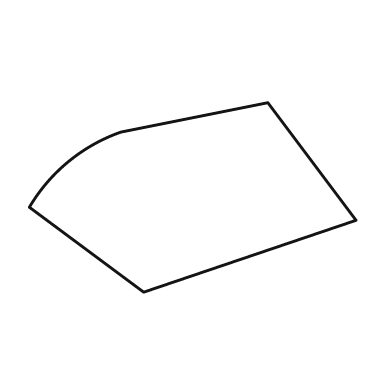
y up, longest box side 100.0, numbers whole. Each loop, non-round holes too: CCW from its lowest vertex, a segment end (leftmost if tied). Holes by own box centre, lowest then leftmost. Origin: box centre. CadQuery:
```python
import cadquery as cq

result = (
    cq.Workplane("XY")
    .moveTo(-15.0, -29.0)
    .lineTo(50.0, -7.0)
    .lineTo(23.0, 29.0)
    .lineTo(-22.0, 20.0)
    .threePointArc((-38.0, 11.0), (-50.0, -3.0))
    .close()
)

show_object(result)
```